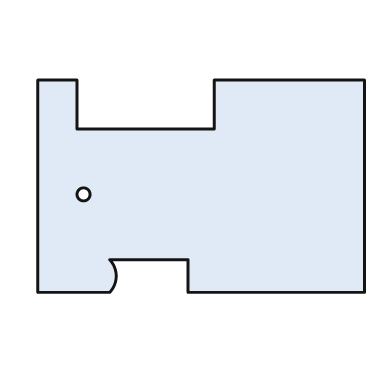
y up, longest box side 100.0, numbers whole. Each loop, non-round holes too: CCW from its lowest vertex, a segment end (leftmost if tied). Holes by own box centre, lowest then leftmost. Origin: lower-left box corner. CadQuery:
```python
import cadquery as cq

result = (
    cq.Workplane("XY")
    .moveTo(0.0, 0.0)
    .lineTo(22.0, 0.0)
    .threePointArc((24.0, 5.0), (22.0, 10.0))
    .lineTo(46.0, 10.0)
    .lineTo(46.0, 0.0)
    .lineTo(100.0, 0.0)
    .lineTo(100.0, 65.0)
    .lineTo(54.0, 65.0)
    .lineTo(54.0, 50.0)
    .lineTo(12.0, 50.0)
    .lineTo(12.0, 65.0)
    .lineTo(0.0, 65.0)
    .close()
    .moveTo(14.0, 30.0)
    .circle(2.0)
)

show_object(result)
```